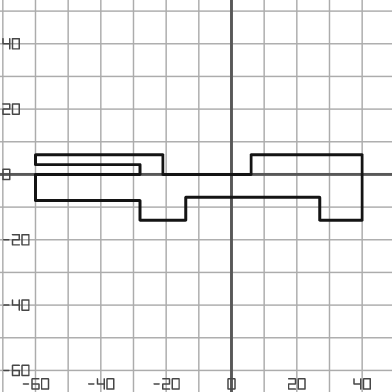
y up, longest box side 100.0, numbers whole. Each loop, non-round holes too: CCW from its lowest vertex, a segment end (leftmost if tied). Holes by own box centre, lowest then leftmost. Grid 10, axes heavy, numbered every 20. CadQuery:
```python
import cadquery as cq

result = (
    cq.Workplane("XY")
    .moveTo(-28.0, -14.0)
    .lineTo(-14.0, -14.0)
    .lineTo(-14.0, -7.0)
    .lineTo(27.0, -7.0)
    .lineTo(27.0, -14.0)
    .lineTo(40.0, -14.0)
    .lineTo(40.0, 6.0)
    .lineTo(6.0, 6.0)
    .lineTo(6.0, 0.0)
    .lineTo(-21.0, 0.0)
    .lineTo(-21.0, 6.0)
    .lineTo(-60.0, 6.0)
    .lineTo(-60.0, 3.0)
    .lineTo(-28.0, 3.0)
    .lineTo(-28.0, 0.0)
    .lineTo(-60.0, 0.0)
    .lineTo(-60.0, -8.0)
    .lineTo(-28.0, -8.0)
    .close()
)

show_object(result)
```